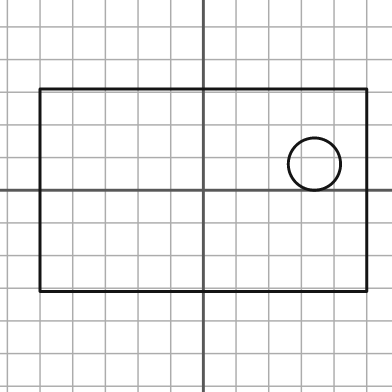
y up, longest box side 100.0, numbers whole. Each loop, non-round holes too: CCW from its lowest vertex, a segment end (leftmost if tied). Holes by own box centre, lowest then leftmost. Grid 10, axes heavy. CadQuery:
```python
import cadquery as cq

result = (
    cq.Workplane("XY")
    .moveTo(-50.0, -31.0)
    .lineTo(50.0, -31.0)
    .lineTo(50.0, 31.0)
    .lineTo(-50.0, 31.0)
    .close()
    .moveTo(34.0, 8.0)
    .circle(8.0)
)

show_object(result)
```